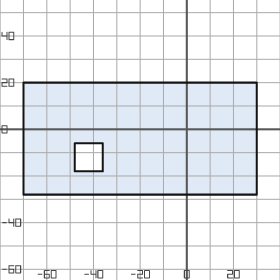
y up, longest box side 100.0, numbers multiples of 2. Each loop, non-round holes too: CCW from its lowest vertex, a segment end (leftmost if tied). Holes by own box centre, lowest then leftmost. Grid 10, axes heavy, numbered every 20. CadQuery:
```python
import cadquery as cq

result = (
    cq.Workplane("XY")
    .moveTo(-70.0, -28.0)
    .lineTo(30.0, -28.0)
    .lineTo(30.0, 20.0)
    .lineTo(-70.0, 20.0)
    .close()
    .moveTo(-48.0, -18.0)
    .lineTo(-36.0, -18.0)
    .lineTo(-36.0, -6.0)
    .lineTo(-48.0, -6.0)
    .close()
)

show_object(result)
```